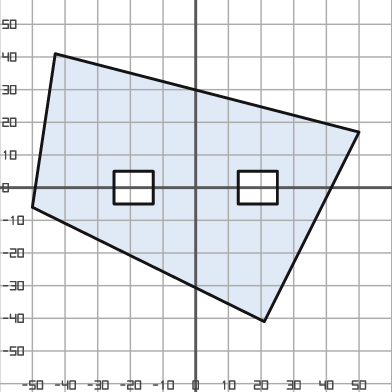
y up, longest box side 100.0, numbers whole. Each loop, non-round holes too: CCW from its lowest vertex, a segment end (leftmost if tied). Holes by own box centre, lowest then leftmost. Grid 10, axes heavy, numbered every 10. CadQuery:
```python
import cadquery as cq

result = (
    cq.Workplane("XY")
    .moveTo(21.0, -41.0)
    .lineTo(50.0, 17.0)
    .lineTo(-43.0, 41.0)
    .lineTo(-50.0, -6.0)
    .close()
    .moveTo(-25.0, -5.0)
    .lineTo(-13.0, -5.0)
    .lineTo(-13.0, 5.0)
    .lineTo(-25.0, 5.0)
    .close()
    .moveTo(13.0, -5.0)
    .lineTo(25.0, -5.0)
    .lineTo(25.0, 5.0)
    .lineTo(13.0, 5.0)
    .close()
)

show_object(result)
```